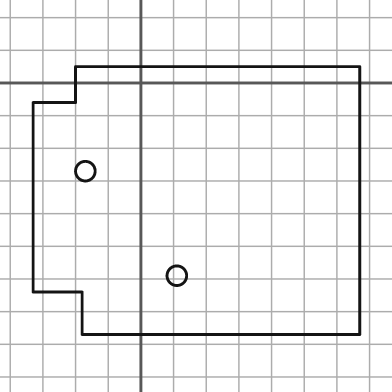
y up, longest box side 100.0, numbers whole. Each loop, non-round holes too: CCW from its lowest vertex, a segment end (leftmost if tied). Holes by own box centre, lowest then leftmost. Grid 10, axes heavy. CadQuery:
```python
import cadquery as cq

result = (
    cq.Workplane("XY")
    .moveTo(-18.0, -77.0)
    .lineTo(67.0, -77.0)
    .lineTo(67.0, 5.0)
    .lineTo(-20.0, 5.0)
    .lineTo(-20.0, -6.0)
    .lineTo(-33.0, -6.0)
    .lineTo(-33.0, -64.0)
    .lineTo(-18.0, -64.0)
    .close()
    .moveTo(11.0, -59.0)
    .circle(3.0)
    .moveTo(-17.0, -27.0)
    .circle(3.0)
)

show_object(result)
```